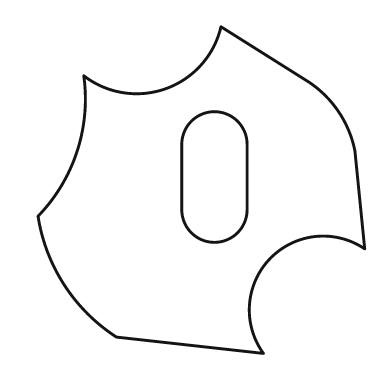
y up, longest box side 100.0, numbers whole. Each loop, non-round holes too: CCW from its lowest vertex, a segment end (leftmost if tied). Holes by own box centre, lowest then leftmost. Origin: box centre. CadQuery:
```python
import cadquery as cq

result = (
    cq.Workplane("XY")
    .moveTo(19.0, -50.0)
    .threePointArc((21.0, -21.0), (50.0, -18.0))
    .lineTo(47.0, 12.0)
    .threePointArc((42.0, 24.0), (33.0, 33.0))
    .lineTo(6.0, 50.0)
    .threePointArc((-11.0, 31.0), (-36.0, 35.0))
    .threePointArc((-38.0, 12.0), (-50.0, -8.0))
    .threePointArc((-42.0, -29.0), (-26.0, -45.0))
    .close()
    .moveTo(-6.0, -6.0)
    .threePointArc((4.0, -16.0), (14.0, -6.0))
    .lineTo(14.0, 14.0)
    .threePointArc((4.0, 24.0), (-6.0, 14.0))
    .close()
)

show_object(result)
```